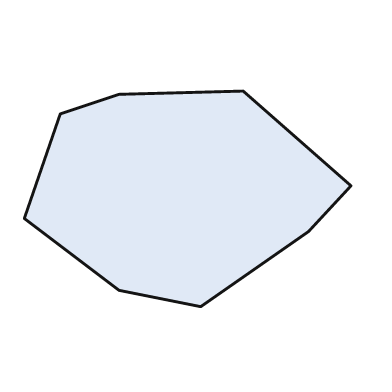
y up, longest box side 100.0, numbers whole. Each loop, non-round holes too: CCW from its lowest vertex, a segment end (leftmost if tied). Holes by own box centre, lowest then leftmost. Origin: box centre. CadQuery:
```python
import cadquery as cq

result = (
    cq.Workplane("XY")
    .moveTo(4.0, -33.0)
    .lineTo(37.0, -10.0)
    .lineTo(50.0, 4.0)
    .lineTo(17.0, 33.0)
    .lineTo(-21.0, 32.0)
    .lineTo(-39.0, 26.0)
    .lineTo(-50.0, -6.0)
    .lineTo(-21.0, -28.0)
    .close()
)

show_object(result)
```